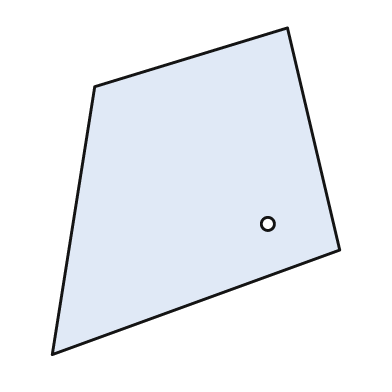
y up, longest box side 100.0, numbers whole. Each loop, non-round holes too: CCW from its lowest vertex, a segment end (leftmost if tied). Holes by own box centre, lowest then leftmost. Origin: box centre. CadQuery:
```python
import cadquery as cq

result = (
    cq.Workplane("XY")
    .moveTo(-44.0, -50.0)
    .lineTo(44.0, -18.0)
    .lineTo(28.0, 50.0)
    .lineTo(-31.0, 32.0)
    .close()
    .moveTo(22.0, -10.0)
    .circle(2.0)
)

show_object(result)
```